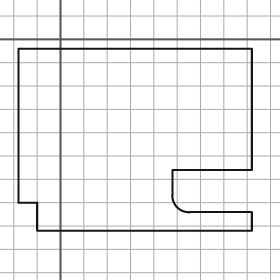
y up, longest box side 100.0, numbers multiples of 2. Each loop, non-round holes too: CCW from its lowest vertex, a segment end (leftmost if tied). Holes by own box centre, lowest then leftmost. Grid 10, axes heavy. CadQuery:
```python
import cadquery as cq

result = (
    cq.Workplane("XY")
    .moveTo(-10.0, -82.0)
    .lineTo(82.0, -82.0)
    .lineTo(82.0, -74.0)
    .lineTo(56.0, -74.0)
    .threePointArc((50.0, -72.0), (48.0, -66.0))
    .lineTo(48.0, -56.0)
    .lineTo(82.0, -56.0)
    .lineTo(82.0, -4.0)
    .lineTo(-18.0, -4.0)
    .lineTo(-18.0, -70.0)
    .lineTo(-10.0, -70.0)
    .close()
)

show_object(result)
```